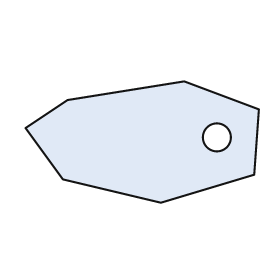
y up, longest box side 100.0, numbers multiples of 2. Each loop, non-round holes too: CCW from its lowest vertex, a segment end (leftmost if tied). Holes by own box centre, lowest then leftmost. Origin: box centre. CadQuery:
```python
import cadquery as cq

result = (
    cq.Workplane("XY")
    .moveTo(8.0, -26.0)
    .lineTo(48.0, -14.0)
    .lineTo(50.0, 14.0)
    .lineTo(18.0, 26.0)
    .lineTo(-32.0, 18.0)
    .lineTo(-50.0, 6.0)
    .lineTo(-34.0, -16.0)
    .close()
    .moveTo(32.0, 2.0)
    .circle(6.0)
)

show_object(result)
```